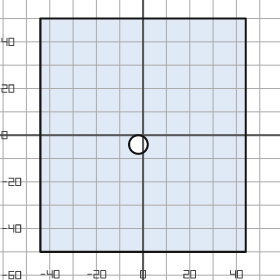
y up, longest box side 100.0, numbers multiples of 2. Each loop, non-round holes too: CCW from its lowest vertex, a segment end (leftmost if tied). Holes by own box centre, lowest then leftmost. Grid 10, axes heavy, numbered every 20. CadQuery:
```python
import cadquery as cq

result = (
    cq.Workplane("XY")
    .moveTo(-44.0, -50.0)
    .lineTo(44.0, -50.0)
    .lineTo(44.0, 50.0)
    .lineTo(-44.0, 50.0)
    .close()
    .moveTo(-2.0, -4.0)
    .circle(4.0)
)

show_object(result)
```